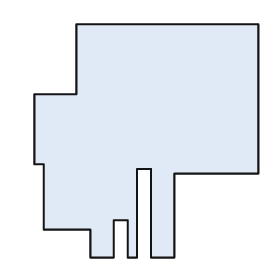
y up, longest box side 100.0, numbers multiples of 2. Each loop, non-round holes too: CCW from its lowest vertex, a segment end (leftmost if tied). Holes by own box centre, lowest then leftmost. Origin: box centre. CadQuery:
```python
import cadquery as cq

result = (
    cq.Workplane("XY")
    .moveTo(-24.0, -50.0)
    .lineTo(-14.0, -50.0)
    .lineTo(-14.0, -34.0)
    .lineTo(-8.0, -34.0)
    .lineTo(-8.0, -50.0)
    .lineTo(-4.0, -50.0)
    .lineTo(-4.0, -12.0)
    .lineTo(2.0, -12.0)
    .lineTo(2.0, -50.0)
    .lineTo(12.0, -50.0)
    .lineTo(12.0, -14.0)
    .lineTo(48.0, -14.0)
    .lineTo(48.0, 50.0)
    .lineTo(-30.0, 50.0)
    .lineTo(-30.0, 20.0)
    .lineTo(-48.0, 20.0)
    .lineTo(-48.0, -10.0)
    .lineTo(-44.0, -10.0)
    .lineTo(-44.0, -38.0)
    .lineTo(-24.0, -38.0)
    .close()
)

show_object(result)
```